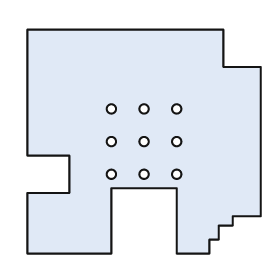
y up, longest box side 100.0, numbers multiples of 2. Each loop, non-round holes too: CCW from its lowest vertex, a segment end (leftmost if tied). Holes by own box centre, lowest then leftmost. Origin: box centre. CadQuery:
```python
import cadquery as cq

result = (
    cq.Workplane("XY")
    .moveTo(-50.0, -48.0)
    .lineTo(-14.0, -48.0)
    .lineTo(-14.0, -20.0)
    .lineTo(14.0, -20.0)
    .lineTo(14.0, -48.0)
    .lineTo(28.0, -48.0)
    .lineTo(28.0, -42.0)
    .lineTo(32.0, -42.0)
    .lineTo(32.0, -36.0)
    .lineTo(38.0, -36.0)
    .lineTo(38.0, -32.0)
    .lineTo(50.0, -32.0)
    .lineTo(50.0, 32.0)
    .lineTo(34.0, 32.0)
    .lineTo(34.0, 48.0)
    .lineTo(-50.0, 48.0)
    .lineTo(-50.0, -6.0)
    .lineTo(-32.0, -6.0)
    .lineTo(-32.0, -22.0)
    .lineTo(-50.0, -22.0)
    .close()
    .moveTo(-14.0, -14.0)
    .circle(2.0)
    .moveTo(0.0, -14.0)
    .circle(2.0)
    .moveTo(14.0, -14.0)
    .circle(2.0)
    .moveTo(-14.0, 0.0)
    .circle(2.0)
    .moveTo(0.0, 0.0)
    .circle(2.0)
    .moveTo(14.0, 0.0)
    .circle(2.0)
    .moveTo(-14.0, 14.0)
    .circle(2.0)
    .moveTo(0.0, 14.0)
    .circle(2.0)
    .moveTo(14.0, 14.0)
    .circle(2.0)
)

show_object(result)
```